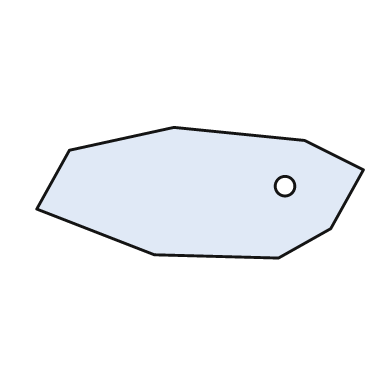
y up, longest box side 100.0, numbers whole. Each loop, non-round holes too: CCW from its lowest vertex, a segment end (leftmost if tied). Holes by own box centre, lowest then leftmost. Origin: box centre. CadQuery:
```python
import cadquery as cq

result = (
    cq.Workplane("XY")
    .moveTo(24.0, -20.0)
    .lineTo(40.0, -11.0)
    .lineTo(50.0, 7.0)
    .lineTo(32.0, 16.0)
    .lineTo(-8.0, 20.0)
    .lineTo(-40.0, 13.0)
    .lineTo(-50.0, -5.0)
    .lineTo(-14.0, -19.0)
    .close()
    .moveTo(26.0, 2.0)
    .circle(3.0)
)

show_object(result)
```